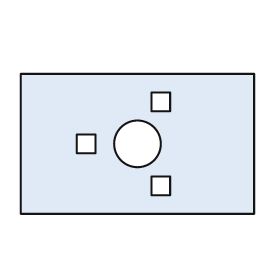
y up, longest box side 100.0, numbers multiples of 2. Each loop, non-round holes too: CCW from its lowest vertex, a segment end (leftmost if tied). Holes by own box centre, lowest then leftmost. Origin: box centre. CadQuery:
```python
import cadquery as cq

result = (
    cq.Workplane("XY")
    .moveTo(-50.0, -30.0)
    .lineTo(50.0, -30.0)
    .lineTo(50.0, 30.0)
    .lineTo(-50.0, 30.0)
    .close()
    .moveTo(6.0, -22.0)
    .lineTo(14.0, -22.0)
    .lineTo(14.0, -14.0)
    .lineTo(6.0, -14.0)
    .close()
    .moveTo(-26.0, -4.0)
    .lineTo(-18.0, -4.0)
    .lineTo(-18.0, 4.0)
    .lineTo(-26.0, 4.0)
    .close()
    .moveTo(0.0, 0.0)
    .circle(10.0)
    .moveTo(6.0, 14.0)
    .lineTo(14.0, 14.0)
    .lineTo(14.0, 22.0)
    .lineTo(6.0, 22.0)
    .close()
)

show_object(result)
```